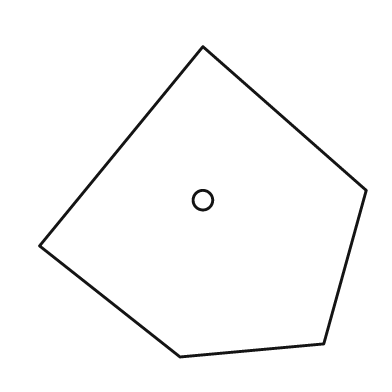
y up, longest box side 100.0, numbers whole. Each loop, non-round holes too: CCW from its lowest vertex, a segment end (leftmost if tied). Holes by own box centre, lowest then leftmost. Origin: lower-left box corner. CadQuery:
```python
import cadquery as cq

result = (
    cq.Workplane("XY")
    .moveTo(43.0, 0.0)
    .lineTo(87.0, 4.0)
    .lineTo(100.0, 51.0)
    .lineTo(50.0, 95.0)
    .lineTo(0.0, 34.0)
    .close()
    .moveTo(50.0, 48.0)
    .circle(3.0)
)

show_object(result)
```